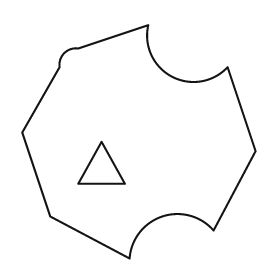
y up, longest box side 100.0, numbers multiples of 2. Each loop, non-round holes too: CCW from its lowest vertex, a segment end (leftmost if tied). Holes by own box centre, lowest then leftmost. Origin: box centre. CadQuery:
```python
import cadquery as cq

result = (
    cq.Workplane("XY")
    .moveTo(-4.0, -50.0)
    .threePointArc((10.0, -32.0), (32.0, -38.0))
    .lineTo(50.0, -4.0)
    .lineTo(38.0, 32.0)
    .threePointArc((14.0, 28.0), (4.0, 50.0))
    .lineTo(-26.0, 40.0)
    .threePointArc((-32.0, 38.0), (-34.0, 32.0))
    .lineTo(-50.0, 4.0)
    .lineTo(-38.0, -32.0)
    .close()
    .moveTo(-26.0, -18.0)
    .lineTo(-6.0, -18.0)
    .lineTo(-16.0, 0.0)
    .close()
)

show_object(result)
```